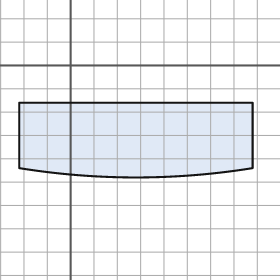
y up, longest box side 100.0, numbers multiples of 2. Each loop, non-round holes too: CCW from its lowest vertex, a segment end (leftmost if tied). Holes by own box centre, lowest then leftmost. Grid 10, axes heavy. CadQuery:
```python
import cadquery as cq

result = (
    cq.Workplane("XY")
    .moveTo(-22.0, -44.0)
    .threePointArc((28.0, -48.0), (78.0, -44.0))
    .lineTo(78.0, -16.0)
    .lineTo(-22.0, -16.0)
    .close()
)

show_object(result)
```